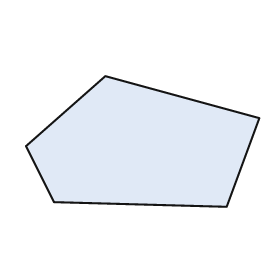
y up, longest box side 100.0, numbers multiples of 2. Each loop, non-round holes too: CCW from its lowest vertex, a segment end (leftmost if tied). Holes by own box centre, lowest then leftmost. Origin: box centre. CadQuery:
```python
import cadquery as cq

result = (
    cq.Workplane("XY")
    .moveTo(36.0, -28.0)
    .lineTo(50.0, 10.0)
    .lineTo(-16.0, 28.0)
    .lineTo(-50.0, -2.0)
    .lineTo(-38.0, -26.0)
    .close()
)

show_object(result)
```